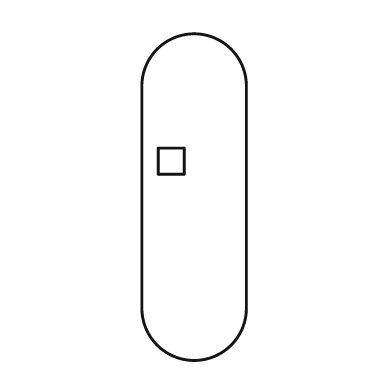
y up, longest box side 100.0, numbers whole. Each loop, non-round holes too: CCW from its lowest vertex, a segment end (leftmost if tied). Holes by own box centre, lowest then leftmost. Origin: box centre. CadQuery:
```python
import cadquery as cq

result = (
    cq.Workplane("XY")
    .moveTo(-16.0, -34.0)
    .threePointArc((0.0, -50.0), (16.0, -34.0))
    .lineTo(16.0, 34.0)
    .threePointArc((0.0, 50.0), (-16.0, 34.0))
    .close()
    .moveTo(-11.0, 7.0)
    .lineTo(-3.0, 7.0)
    .lineTo(-3.0, 15.0)
    .lineTo(-11.0, 15.0)
    .close()
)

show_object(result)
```